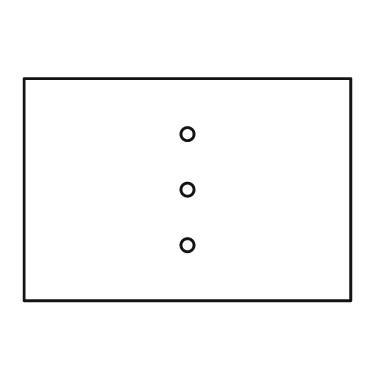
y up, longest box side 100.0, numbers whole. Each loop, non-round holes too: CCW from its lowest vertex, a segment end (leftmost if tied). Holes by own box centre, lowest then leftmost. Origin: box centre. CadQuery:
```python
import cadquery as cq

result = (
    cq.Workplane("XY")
    .moveTo(-50.0, -34.0)
    .lineTo(50.0, -34.0)
    .lineTo(50.0, 34.0)
    .lineTo(-50.0, 34.0)
    .close()
    .moveTo(0.0, -17.0)
    .circle(2.0)
    .moveTo(0.0, 0.0)
    .circle(2.0)
    .moveTo(0.0, 17.0)
    .circle(2.0)
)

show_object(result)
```